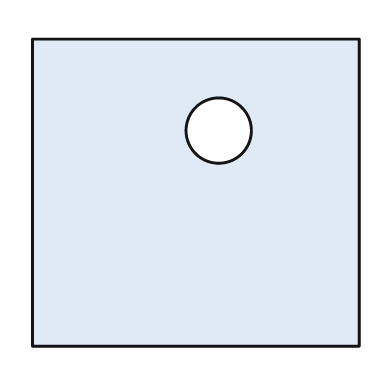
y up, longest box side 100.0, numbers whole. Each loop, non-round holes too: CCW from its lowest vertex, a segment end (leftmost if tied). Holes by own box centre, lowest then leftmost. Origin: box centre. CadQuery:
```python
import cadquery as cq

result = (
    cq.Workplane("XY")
    .moveTo(-50.0, -47.0)
    .lineTo(50.0, -47.0)
    .lineTo(50.0, 47.0)
    .lineTo(-50.0, 47.0)
    .close()
    .moveTo(7.0, 19.0)
    .circle(10.0)
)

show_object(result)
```